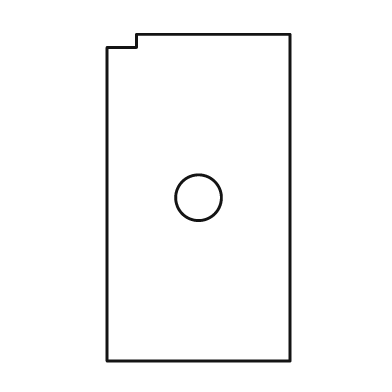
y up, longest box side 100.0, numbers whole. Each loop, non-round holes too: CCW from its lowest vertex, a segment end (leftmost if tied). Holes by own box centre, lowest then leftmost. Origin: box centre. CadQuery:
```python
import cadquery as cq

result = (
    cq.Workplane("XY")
    .moveTo(-28.0, -50.0)
    .lineTo(28.0, -50.0)
    .lineTo(28.0, 50.0)
    .lineTo(-19.0, 50.0)
    .lineTo(-19.0, 46.0)
    .lineTo(-28.0, 46.0)
    .close()
    .moveTo(0.0, 0.0)
    .circle(7.0)
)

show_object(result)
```